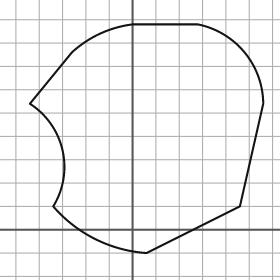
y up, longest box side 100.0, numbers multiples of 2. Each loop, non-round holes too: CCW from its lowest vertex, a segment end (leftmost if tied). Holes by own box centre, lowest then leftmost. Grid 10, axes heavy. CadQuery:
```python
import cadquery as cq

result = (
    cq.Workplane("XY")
    .moveTo(6.0, -10.0)
    .lineTo(46.0, 10.0)
    .lineTo(56.0, 54.0)
    .threePointArc((48.0, 76.0), (28.0, 88.0))
    .lineTo(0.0, 88.0)
    .threePointArc((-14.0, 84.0), (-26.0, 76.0))
    .lineTo(-44.0, 54.0)
    .threePointArc((-30.0, 34.0), (-34.0, 10.0))
    .threePointArc((-16.0, -4.0), (6.0, -10.0))
    .close()
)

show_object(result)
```